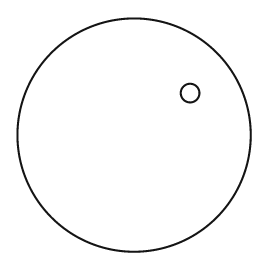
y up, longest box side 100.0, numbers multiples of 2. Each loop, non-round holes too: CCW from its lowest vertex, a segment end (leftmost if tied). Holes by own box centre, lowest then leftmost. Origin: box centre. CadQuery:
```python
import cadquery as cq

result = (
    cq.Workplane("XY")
    .moveTo(0.0, 0.0)
    .circle(50.0)
    .moveTo(24.0, 18.0)
    .circle(4.0)
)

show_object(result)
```